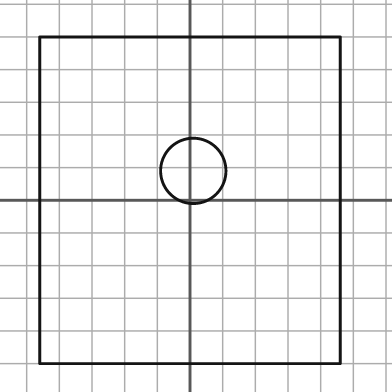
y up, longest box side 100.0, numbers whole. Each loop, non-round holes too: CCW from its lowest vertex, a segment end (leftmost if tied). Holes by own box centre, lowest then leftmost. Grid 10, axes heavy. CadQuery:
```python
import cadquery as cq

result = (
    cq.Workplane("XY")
    .moveTo(-46.0, -50.0)
    .lineTo(46.0, -50.0)
    .lineTo(46.0, 50.0)
    .lineTo(-46.0, 50.0)
    .close()
    .moveTo(1.0, 9.0)
    .circle(10.0)
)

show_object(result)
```